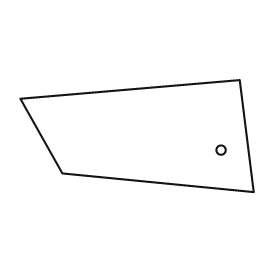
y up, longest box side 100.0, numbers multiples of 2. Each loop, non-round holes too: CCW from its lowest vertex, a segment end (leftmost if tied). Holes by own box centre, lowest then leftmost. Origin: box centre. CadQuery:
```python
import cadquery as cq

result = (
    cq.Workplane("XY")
    .moveTo(50.0, -24.0)
    .lineTo(44.0, 24.0)
    .lineTo(-50.0, 16.0)
    .lineTo(-32.0, -16.0)
    .close()
    .moveTo(36.0, -6.0)
    .circle(2.0)
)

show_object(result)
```